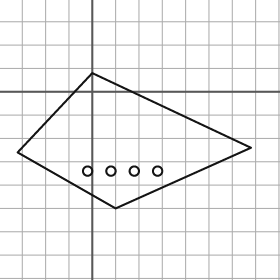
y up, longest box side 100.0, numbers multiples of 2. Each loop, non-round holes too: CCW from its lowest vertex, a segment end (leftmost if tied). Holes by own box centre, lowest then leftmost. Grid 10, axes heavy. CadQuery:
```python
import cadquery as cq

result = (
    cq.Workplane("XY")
    .moveTo(10.0, -50.0)
    .lineTo(68.0, -24.0)
    .lineTo(0.0, 8.0)
    .lineTo(-32.0, -26.0)
    .close()
    .moveTo(-2.0, -34.0)
    .circle(2.0)
    .moveTo(8.0, -34.0)
    .circle(2.0)
    .moveTo(18.0, -34.0)
    .circle(2.0)
    .moveTo(28.0, -34.0)
    .circle(2.0)
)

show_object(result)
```